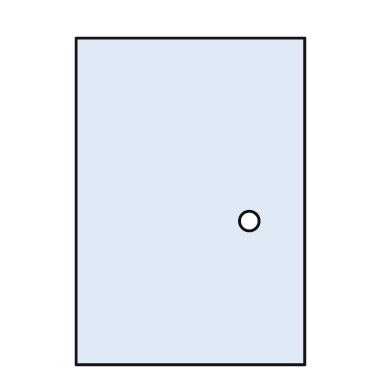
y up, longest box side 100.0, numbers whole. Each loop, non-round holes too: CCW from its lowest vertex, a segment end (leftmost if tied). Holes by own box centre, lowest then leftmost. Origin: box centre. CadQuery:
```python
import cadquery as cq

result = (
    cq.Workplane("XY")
    .moveTo(-35.0, -50.0)
    .lineTo(35.0, -50.0)
    .lineTo(35.0, 50.0)
    .lineTo(-35.0, 50.0)
    .close()
    .moveTo(18.0, -6.0)
    .circle(3.0)
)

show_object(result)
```